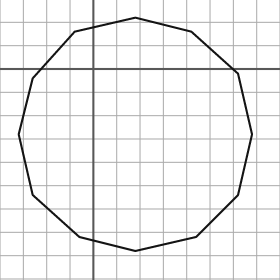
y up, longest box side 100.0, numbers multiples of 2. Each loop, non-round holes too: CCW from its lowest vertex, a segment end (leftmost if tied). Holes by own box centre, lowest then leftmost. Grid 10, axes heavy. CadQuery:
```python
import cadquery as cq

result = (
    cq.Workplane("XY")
    .moveTo(18.0, -78.0)
    .lineTo(44.0, -72.0)
    .lineTo(62.0, -54.0)
    .lineTo(68.0, -28.0)
    .lineTo(62.0, -2.0)
    .lineTo(42.0, 16.0)
    .lineTo(18.0, 22.0)
    .lineTo(-8.0, 16.0)
    .lineTo(-26.0, -4.0)
    .lineTo(-32.0, -28.0)
    .lineTo(-26.0, -54.0)
    .lineTo(-6.0, -72.0)
    .close()
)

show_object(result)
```